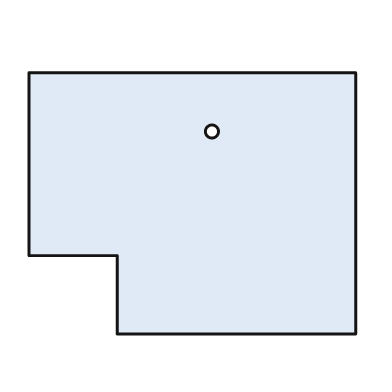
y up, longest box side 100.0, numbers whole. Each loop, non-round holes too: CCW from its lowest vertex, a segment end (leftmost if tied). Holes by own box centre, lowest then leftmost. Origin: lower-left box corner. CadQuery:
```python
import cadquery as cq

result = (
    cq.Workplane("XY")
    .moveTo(27.0, 0.0)
    .lineTo(100.0, 0.0)
    .lineTo(100.0, 80.0)
    .lineTo(0.0, 80.0)
    .lineTo(0.0, 24.0)
    .lineTo(27.0, 24.0)
    .close()
    .moveTo(56.0, 62.0)
    .circle(2.0)
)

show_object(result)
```